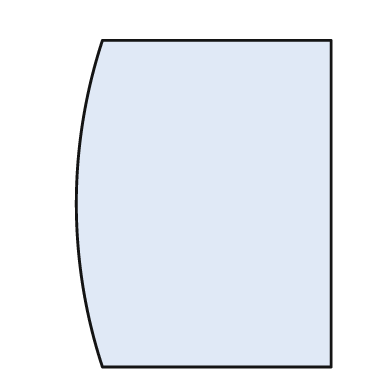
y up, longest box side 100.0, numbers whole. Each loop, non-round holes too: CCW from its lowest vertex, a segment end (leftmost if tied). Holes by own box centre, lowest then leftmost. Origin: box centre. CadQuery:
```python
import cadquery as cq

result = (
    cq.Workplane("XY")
    .moveTo(-31.0, -50.0)
    .lineTo(39.0, -50.0)
    .lineTo(39.0, 50.0)
    .lineTo(-31.0, 50.0)
    .threePointArc((-39.0, 0.0), (-31.0, -50.0))
    .close()
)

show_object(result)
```